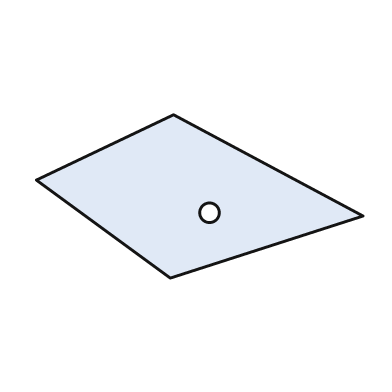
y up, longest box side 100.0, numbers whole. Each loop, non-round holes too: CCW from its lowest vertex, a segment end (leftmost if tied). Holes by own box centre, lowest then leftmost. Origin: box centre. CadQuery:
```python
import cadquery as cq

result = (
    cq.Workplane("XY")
    .moveTo(-9.0, -25.0)
    .lineTo(50.0, -6.0)
    .lineTo(-8.0, 25.0)
    .lineTo(-50.0, 5.0)
    .close()
    .moveTo(3.0, -5.0)
    .circle(3.0)
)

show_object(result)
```